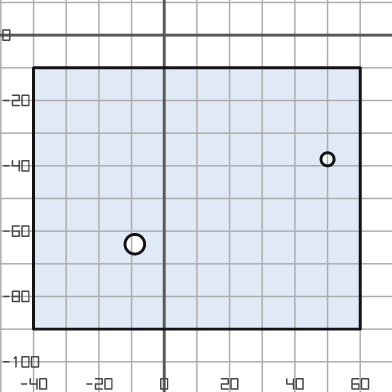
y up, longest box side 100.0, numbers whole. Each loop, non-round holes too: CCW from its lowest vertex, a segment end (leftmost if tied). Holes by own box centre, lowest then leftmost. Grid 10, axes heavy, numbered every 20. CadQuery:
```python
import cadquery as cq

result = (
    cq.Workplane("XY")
    .moveTo(-40.0, -90.0)
    .lineTo(60.0, -90.0)
    .lineTo(60.0, -10.0)
    .lineTo(-40.0, -10.0)
    .close()
    .moveTo(-9.0, -64.0)
    .circle(3.0)
    .moveTo(50.0, -38.0)
    .circle(2.0)
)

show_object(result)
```